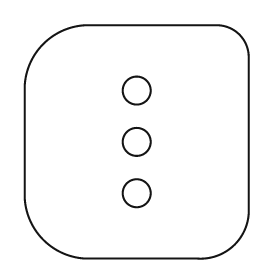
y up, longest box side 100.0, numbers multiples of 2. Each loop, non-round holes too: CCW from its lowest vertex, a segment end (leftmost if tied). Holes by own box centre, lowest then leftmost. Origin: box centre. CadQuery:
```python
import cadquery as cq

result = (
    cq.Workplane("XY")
    .moveTo(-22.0, -50.0)
    .lineTo(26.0, -50.0)
    .threePointArc((42.0, -44.0), (48.0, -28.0))
    .lineTo(48.0, 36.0)
    .threePointArc((44.0, 46.0), (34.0, 50.0))
    .lineTo(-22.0, 50.0)
    .threePointArc((-40.0, 42.0), (-48.0, 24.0))
    .lineTo(-48.0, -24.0)
    .threePointArc((-40.0, -42.0), (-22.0, -50.0))
    .close()
    .moveTo(0.0, -22.0)
    .circle(6.0)
    .moveTo(0.0, 0.0)
    .circle(6.0)
    .moveTo(0.0, 22.0)
    .circle(6.0)
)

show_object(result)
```